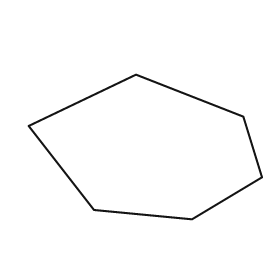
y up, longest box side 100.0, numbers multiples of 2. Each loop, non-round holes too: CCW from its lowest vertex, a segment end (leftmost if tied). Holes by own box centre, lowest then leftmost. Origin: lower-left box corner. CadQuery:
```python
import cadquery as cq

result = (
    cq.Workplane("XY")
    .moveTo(70.0, 0.0)
    .lineTo(100.0, 18.0)
    .lineTo(92.0, 44.0)
    .lineTo(46.0, 62.0)
    .lineTo(0.0, 40.0)
    .lineTo(28.0, 4.0)
    .close()
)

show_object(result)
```